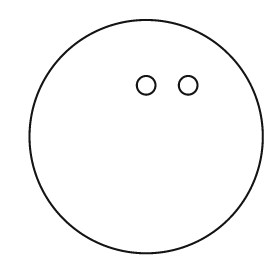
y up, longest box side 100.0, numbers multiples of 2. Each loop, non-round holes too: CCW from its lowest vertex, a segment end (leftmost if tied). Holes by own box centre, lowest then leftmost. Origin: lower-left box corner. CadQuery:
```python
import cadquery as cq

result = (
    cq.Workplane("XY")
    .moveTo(50.0, 50.0)
    .circle(50.0)
    .moveTo(50.0, 72.0)
    .circle(4.0)
    .moveTo(68.0, 72.0)
    .circle(4.0)
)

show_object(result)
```